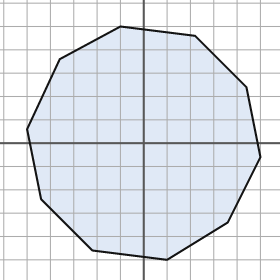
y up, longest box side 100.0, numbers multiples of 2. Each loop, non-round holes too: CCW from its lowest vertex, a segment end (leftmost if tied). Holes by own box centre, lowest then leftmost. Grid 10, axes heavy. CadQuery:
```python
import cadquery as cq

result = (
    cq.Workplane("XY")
    .moveTo(10.0, -50.0)
    .lineTo(36.0, -34.0)
    .lineTo(50.0, -6.0)
    .lineTo(44.0, 24.0)
    .lineTo(22.0, 46.0)
    .lineTo(-10.0, 50.0)
    .lineTo(-36.0, 36.0)
    .lineTo(-50.0, 6.0)
    .lineTo(-44.0, -24.0)
    .lineTo(-22.0, -46.0)
    .close()
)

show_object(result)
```